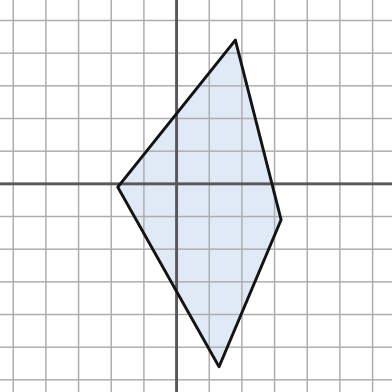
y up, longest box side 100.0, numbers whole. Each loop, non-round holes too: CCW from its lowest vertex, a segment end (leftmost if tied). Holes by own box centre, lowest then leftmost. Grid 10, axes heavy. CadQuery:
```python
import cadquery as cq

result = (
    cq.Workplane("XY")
    .moveTo(13.0, -56.0)
    .lineTo(32.0, -11.0)
    .lineTo(18.0, 44.0)
    .lineTo(-18.0, -1.0)
    .close()
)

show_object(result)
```